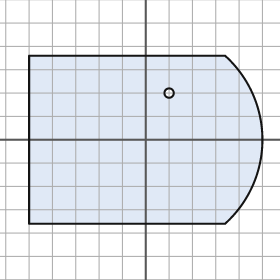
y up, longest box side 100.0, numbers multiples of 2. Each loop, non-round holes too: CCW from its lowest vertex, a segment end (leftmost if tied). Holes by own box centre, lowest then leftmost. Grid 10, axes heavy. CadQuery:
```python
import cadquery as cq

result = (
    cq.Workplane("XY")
    .moveTo(-50.0, -36.0)
    .lineTo(34.0, -36.0)
    .threePointArc((50.0, 0.0), (34.0, 36.0))
    .lineTo(-50.0, 36.0)
    .close()
    .moveTo(10.0, 20.0)
    .circle(2.0)
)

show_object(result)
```